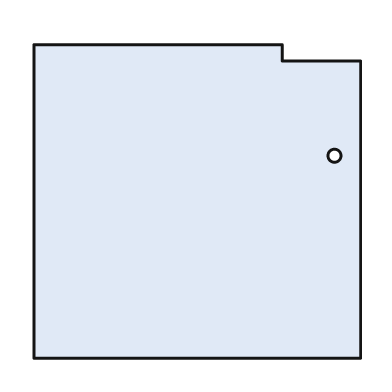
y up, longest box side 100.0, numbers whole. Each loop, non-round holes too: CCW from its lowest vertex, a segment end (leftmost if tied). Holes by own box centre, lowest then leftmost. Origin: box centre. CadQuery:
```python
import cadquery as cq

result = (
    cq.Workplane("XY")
    .moveTo(-50.0, -48.0)
    .lineTo(50.0, -48.0)
    .lineTo(50.0, 43.0)
    .lineTo(26.0, 43.0)
    .lineTo(26.0, 48.0)
    .lineTo(-50.0, 48.0)
    .close()
    .moveTo(42.0, 14.0)
    .circle(2.0)
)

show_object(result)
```